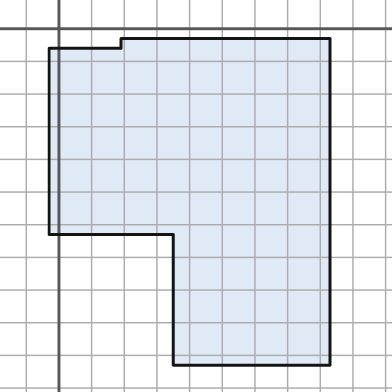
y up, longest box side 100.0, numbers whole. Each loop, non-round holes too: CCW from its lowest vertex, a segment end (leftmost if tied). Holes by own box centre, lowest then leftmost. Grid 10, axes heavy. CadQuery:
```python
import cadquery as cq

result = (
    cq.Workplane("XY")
    .moveTo(35.0, -103.0)
    .lineTo(83.0, -103.0)
    .lineTo(83.0, -3.0)
    .lineTo(19.0, -3.0)
    .lineTo(19.0, -6.0)
    .lineTo(-3.0, -6.0)
    .lineTo(-3.0, -63.0)
    .lineTo(35.0, -63.0)
    .close()
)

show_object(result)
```